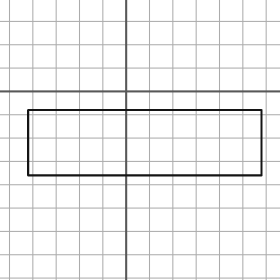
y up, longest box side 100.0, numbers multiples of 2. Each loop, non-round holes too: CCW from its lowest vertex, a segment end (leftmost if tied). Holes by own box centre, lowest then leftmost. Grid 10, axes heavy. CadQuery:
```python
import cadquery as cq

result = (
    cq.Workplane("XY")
    .moveTo(-42.0, -36.0)
    .lineTo(58.0, -36.0)
    .lineTo(58.0, -8.0)
    .lineTo(-42.0, -8.0)
    .close()
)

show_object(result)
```